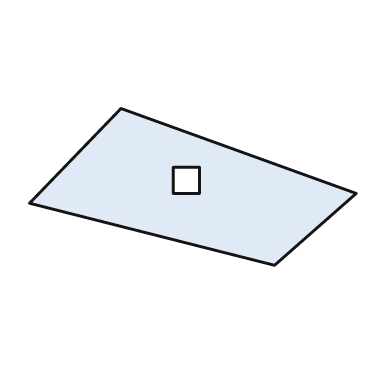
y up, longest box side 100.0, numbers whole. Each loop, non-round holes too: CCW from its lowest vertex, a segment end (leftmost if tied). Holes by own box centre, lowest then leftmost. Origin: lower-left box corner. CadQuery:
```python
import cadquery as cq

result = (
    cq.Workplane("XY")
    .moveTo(75.0, 0.0)
    .lineTo(100.0, 22.0)
    .lineTo(28.0, 48.0)
    .lineTo(0.0, 19.0)
    .close()
    .moveTo(44.0, 22.0)
    .lineTo(52.0, 22.0)
    .lineTo(52.0, 30.0)
    .lineTo(44.0, 30.0)
    .close()
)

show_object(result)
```